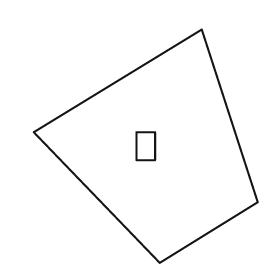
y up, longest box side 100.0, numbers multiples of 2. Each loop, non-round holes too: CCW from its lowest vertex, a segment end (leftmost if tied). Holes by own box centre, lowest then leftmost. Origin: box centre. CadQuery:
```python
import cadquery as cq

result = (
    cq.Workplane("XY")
    .moveTo(6.0, -50.0)
    .lineTo(48.0, -24.0)
    .lineTo(24.0, 50.0)
    .lineTo(-48.0, 6.0)
    .close()
    .moveTo(-4.0, -6.0)
    .lineTo(4.0, -6.0)
    .lineTo(4.0, 6.0)
    .lineTo(-4.0, 6.0)
    .close()
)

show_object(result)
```